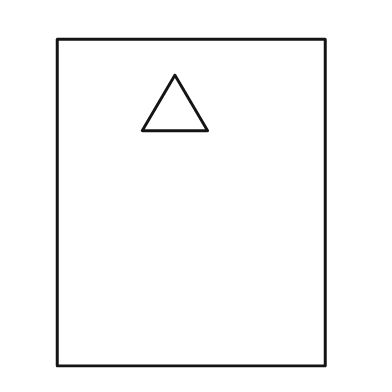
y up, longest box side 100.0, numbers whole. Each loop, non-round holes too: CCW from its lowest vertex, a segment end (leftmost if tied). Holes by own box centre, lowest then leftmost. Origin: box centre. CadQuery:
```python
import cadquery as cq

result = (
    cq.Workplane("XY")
    .moveTo(-41.0, -50.0)
    .lineTo(41.0, -50.0)
    .lineTo(41.0, 50.0)
    .lineTo(-41.0, 50.0)
    .close()
    .moveTo(-15.0, 22.0)
    .lineTo(5.0, 22.0)
    .lineTo(-5.0, 39.0)
    .close()
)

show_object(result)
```